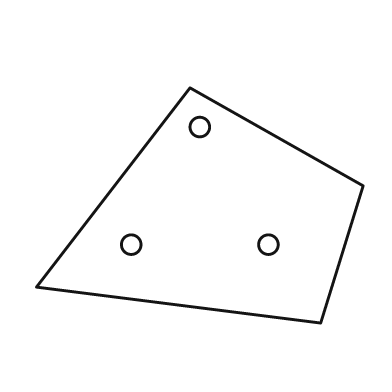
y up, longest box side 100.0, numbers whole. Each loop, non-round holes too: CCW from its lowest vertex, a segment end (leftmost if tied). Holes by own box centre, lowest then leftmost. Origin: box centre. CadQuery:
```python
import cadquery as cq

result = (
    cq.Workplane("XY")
    .moveTo(37.0, -36.0)
    .lineTo(50.0, 6.0)
    .lineTo(-3.0, 36.0)
    .lineTo(-50.0, -25.0)
    .close()
    .moveTo(-21.0, -12.0)
    .circle(3.0)
    .moveTo(21.0, -12.0)
    .circle(3.0)
    .moveTo(0.0, 24.0)
    .circle(3.0)
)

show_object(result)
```